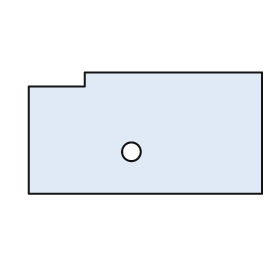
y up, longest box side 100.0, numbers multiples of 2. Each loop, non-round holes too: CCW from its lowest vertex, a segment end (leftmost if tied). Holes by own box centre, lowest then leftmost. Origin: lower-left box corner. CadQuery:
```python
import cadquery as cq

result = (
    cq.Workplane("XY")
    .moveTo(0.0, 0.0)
    .lineTo(100.0, 0.0)
    .lineTo(100.0, 52.0)
    .lineTo(24.0, 52.0)
    .lineTo(24.0, 46.0)
    .lineTo(0.0, 46.0)
    .close()
    .moveTo(44.0, 18.0)
    .circle(4.0)
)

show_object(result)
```